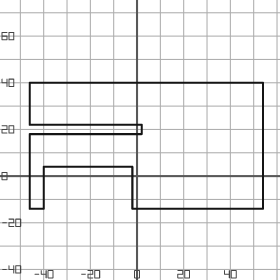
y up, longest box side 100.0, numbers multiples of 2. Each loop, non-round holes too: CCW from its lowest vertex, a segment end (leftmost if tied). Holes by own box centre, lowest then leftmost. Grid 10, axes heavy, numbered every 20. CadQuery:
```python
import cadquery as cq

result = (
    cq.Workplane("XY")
    .moveTo(-46.0, -14.0)
    .lineTo(-40.0, -14.0)
    .lineTo(-40.0, 4.0)
    .lineTo(-2.0, 4.0)
    .lineTo(-2.0, -14.0)
    .lineTo(54.0, -14.0)
    .lineTo(54.0, 40.0)
    .lineTo(-46.0, 40.0)
    .lineTo(-46.0, 22.0)
    .lineTo(2.0, 22.0)
    .lineTo(2.0, 18.0)
    .lineTo(-46.0, 18.0)
    .close()
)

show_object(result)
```